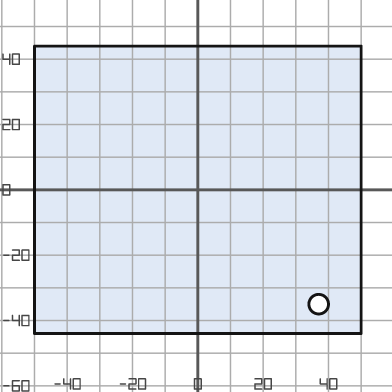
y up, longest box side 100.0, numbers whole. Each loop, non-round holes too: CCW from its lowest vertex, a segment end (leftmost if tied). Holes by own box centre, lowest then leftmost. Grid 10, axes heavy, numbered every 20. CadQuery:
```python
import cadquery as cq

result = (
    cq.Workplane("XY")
    .moveTo(-50.0, -44.0)
    .lineTo(50.0, -44.0)
    .lineTo(50.0, 44.0)
    .lineTo(-50.0, 44.0)
    .close()
    .moveTo(37.0, -35.0)
    .circle(3.0)
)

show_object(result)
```